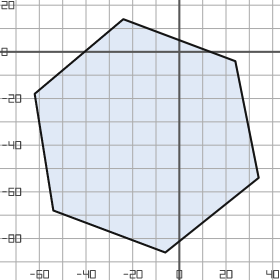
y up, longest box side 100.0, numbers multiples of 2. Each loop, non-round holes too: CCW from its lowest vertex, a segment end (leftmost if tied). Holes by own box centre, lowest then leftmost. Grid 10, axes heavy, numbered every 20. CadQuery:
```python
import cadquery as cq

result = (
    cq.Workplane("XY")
    .moveTo(-6.0, -86.0)
    .lineTo(34.0, -54.0)
    .lineTo(24.0, -4.0)
    .lineTo(-24.0, 14.0)
    .lineTo(-62.0, -18.0)
    .lineTo(-54.0, -68.0)
    .close()
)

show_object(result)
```